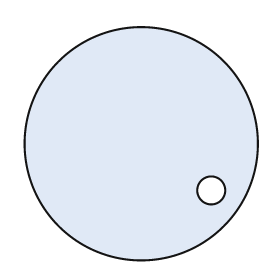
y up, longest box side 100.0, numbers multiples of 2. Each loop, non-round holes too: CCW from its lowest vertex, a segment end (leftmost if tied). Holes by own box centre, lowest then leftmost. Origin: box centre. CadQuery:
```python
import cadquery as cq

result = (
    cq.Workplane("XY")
    .moveTo(0.0, 0.0)
    .circle(50.0)
    .moveTo(30.0, -20.0)
    .circle(6.0)
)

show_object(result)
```